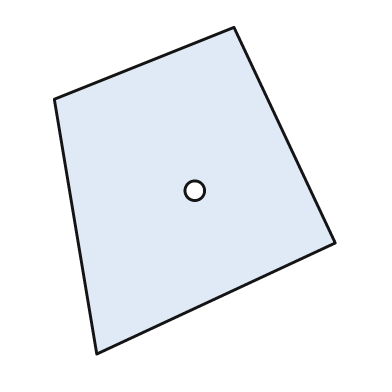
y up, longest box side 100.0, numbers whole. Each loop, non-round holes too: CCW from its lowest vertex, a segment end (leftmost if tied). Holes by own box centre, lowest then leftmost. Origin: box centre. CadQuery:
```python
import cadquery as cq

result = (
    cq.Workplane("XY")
    .moveTo(-30.0, -50.0)
    .lineTo(43.0, -16.0)
    .lineTo(12.0, 50.0)
    .lineTo(-43.0, 28.0)
    .close()
    .moveTo(0.0, 0.0)
    .circle(3.0)
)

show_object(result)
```